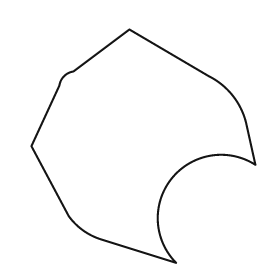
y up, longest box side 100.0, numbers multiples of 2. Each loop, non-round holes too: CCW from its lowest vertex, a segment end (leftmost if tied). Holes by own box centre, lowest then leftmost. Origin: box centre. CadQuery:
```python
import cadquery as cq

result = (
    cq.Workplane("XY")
    .moveTo(14.0, -50.0)
    .threePointArc((12.0, -14.0), (48.0, -8.0))
    .lineTo(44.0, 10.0)
    .threePointArc((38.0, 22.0), (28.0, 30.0))
    .lineTo(-6.0, 50.0)
    .lineTo(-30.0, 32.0)
    .threePointArc((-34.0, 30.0), (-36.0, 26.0))
    .lineTo(-48.0, 0.0)
    .lineTo(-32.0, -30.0)
    .threePointArc((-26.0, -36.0), (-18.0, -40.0))
    .close()
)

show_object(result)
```